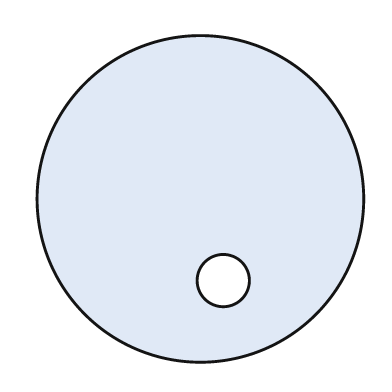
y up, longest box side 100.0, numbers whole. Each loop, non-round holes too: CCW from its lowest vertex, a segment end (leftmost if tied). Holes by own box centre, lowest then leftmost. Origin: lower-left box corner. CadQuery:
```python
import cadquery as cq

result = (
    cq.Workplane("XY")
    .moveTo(50.0, 50.0)
    .circle(50.0)
    .moveTo(57.0, 25.0)
    .circle(8.0)
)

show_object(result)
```